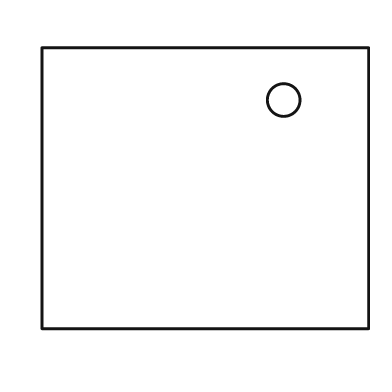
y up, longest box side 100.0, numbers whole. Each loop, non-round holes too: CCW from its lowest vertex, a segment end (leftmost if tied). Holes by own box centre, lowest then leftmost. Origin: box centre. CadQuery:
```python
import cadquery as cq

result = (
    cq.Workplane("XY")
    .moveTo(-50.0, -43.0)
    .lineTo(50.0, -43.0)
    .lineTo(50.0, 43.0)
    .lineTo(-50.0, 43.0)
    .close()
    .moveTo(24.0, 27.0)
    .circle(5.0)
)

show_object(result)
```